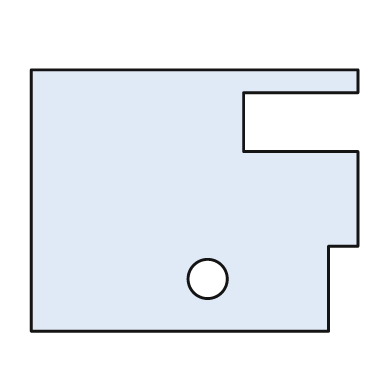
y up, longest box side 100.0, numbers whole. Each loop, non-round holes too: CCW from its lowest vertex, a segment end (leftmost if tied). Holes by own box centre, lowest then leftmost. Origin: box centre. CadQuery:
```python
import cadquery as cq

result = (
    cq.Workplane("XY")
    .moveTo(-50.0, -40.0)
    .lineTo(41.0, -40.0)
    .lineTo(41.0, -14.0)
    .lineTo(50.0, -14.0)
    .lineTo(50.0, 15.0)
    .lineTo(15.0, 15.0)
    .lineTo(15.0, 33.0)
    .lineTo(50.0, 33.0)
    .lineTo(50.0, 40.0)
    .lineTo(-50.0, 40.0)
    .close()
    .moveTo(4.0, -24.0)
    .circle(6.0)
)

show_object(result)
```